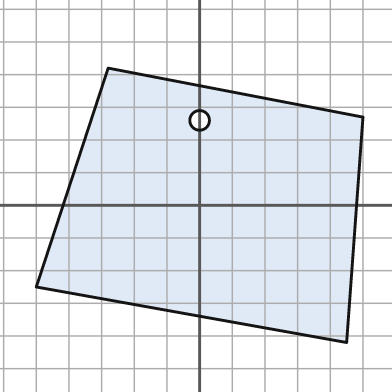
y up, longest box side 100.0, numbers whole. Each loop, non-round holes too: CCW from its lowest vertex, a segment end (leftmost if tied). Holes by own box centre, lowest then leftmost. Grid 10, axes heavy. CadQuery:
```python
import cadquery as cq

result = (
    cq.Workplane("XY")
    .moveTo(45.0, -42.0)
    .lineTo(50.0, 27.0)
    .lineTo(-28.0, 42.0)
    .lineTo(-50.0, -25.0)
    .close()
    .moveTo(0.0, 26.0)
    .circle(3.0)
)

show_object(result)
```